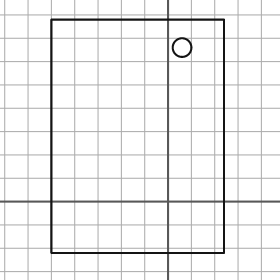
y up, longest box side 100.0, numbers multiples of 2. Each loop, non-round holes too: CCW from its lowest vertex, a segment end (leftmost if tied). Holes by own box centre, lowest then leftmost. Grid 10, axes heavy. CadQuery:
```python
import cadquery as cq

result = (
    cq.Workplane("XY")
    .moveTo(-50.0, -22.0)
    .lineTo(24.0, -22.0)
    .lineTo(24.0, 78.0)
    .lineTo(-50.0, 78.0)
    .close()
    .moveTo(6.0, 66.0)
    .circle(4.0)
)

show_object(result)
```